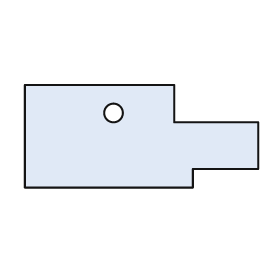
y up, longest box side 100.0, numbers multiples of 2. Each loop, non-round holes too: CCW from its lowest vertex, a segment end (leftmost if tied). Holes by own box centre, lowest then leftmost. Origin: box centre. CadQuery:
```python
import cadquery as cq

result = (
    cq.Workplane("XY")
    .moveTo(-50.0, -22.0)
    .lineTo(22.0, -22.0)
    .lineTo(22.0, -14.0)
    .lineTo(50.0, -14.0)
    .lineTo(50.0, 6.0)
    .lineTo(14.0, 6.0)
    .lineTo(14.0, 22.0)
    .lineTo(-50.0, 22.0)
    .close()
    .moveTo(-12.0, 10.0)
    .circle(4.0)
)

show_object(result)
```